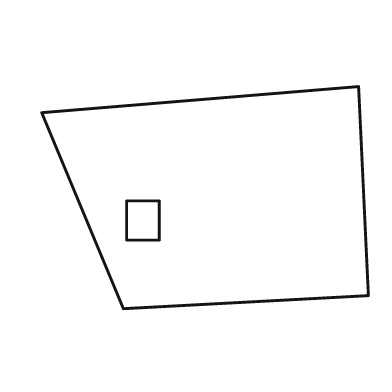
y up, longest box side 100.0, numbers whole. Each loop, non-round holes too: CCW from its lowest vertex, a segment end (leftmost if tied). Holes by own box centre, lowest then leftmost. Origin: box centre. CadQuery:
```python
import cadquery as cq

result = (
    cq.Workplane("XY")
    .moveTo(-25.0, -34.0)
    .lineTo(50.0, -30.0)
    .lineTo(47.0, 34.0)
    .lineTo(-50.0, 26.0)
    .close()
    .moveTo(-24.0, -13.0)
    .lineTo(-14.0, -13.0)
    .lineTo(-14.0, -1.0)
    .lineTo(-24.0, -1.0)
    .close()
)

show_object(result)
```